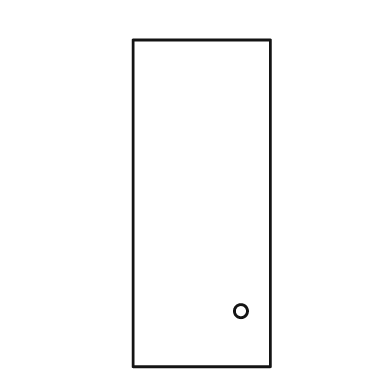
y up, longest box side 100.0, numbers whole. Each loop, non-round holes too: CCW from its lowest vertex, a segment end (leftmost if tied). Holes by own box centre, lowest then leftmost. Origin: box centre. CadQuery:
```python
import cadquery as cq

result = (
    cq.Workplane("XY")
    .moveTo(-21.0, -50.0)
    .lineTo(21.0, -50.0)
    .lineTo(21.0, 50.0)
    .lineTo(-21.0, 50.0)
    .close()
    .moveTo(12.0, -33.0)
    .circle(2.0)
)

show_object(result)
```